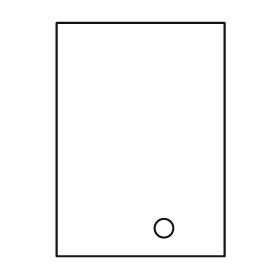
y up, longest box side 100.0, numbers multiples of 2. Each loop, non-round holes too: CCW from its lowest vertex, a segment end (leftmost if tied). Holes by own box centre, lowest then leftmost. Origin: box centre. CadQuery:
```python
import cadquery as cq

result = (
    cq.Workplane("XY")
    .moveTo(-36.0, -50.0)
    .lineTo(36.0, -50.0)
    .lineTo(36.0, 50.0)
    .lineTo(-36.0, 50.0)
    .close()
    .moveTo(10.0, -38.0)
    .circle(4.0)
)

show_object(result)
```